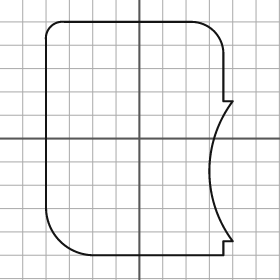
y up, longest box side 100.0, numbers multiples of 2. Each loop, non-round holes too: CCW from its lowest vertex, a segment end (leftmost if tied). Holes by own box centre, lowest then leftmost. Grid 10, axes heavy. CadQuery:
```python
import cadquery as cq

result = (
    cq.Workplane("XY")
    .moveTo(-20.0, -50.0)
    .lineTo(36.0, -50.0)
    .lineTo(36.0, -44.0)
    .lineTo(40.0, -44.0)
    .threePointArc((30.0, -14.0), (40.0, 16.0))
    .lineTo(36.0, 16.0)
    .lineTo(36.0, 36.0)
    .threePointArc((32.0, 46.0), (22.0, 50.0))
    .lineTo(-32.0, 50.0)
    .threePointArc((-38.0, 48.0), (-40.0, 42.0))
    .lineTo(-40.0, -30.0)
    .threePointArc((-34.0, -44.0), (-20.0, -50.0))
    .close()
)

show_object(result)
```